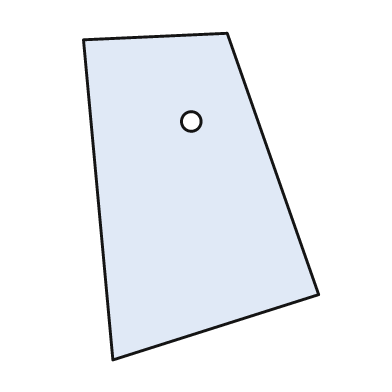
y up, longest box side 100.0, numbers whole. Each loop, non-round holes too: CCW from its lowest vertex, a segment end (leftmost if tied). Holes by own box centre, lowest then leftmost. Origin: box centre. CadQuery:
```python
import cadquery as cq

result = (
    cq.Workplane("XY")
    .moveTo(-27.0, -50.0)
    .lineTo(36.0, -30.0)
    .lineTo(8.0, 50.0)
    .lineTo(-36.0, 48.0)
    .close()
    .moveTo(-3.0, 23.0)
    .circle(3.0)
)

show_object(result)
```